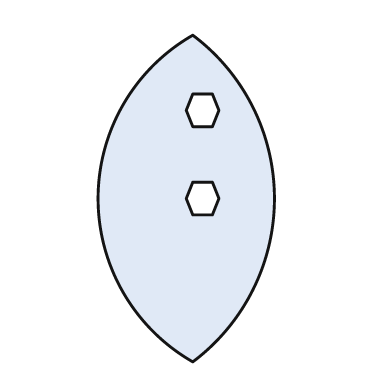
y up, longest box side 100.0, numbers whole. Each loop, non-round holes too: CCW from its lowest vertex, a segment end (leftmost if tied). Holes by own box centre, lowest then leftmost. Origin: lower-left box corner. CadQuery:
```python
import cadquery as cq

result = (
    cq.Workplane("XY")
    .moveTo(29.0, 0.0)
    .threePointArc((54.0, 50.0), (29.0, 100.0))
    .threePointArc((0.0, 50.0), (29.0, 0.0))
    .close()
    .moveTo(29.0, 45.0)
    .lineTo(35.0, 45.0)
    .lineTo(37.0, 50.0)
    .lineTo(35.0, 55.0)
    .lineTo(29.0, 55.0)
    .lineTo(27.0, 50.0)
    .close()
    .moveTo(29.0, 72.0)
    .lineTo(35.0, 72.0)
    .lineTo(37.0, 77.0)
    .lineTo(35.0, 82.0)
    .lineTo(29.0, 82.0)
    .lineTo(27.0, 77.0)
    .close()
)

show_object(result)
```